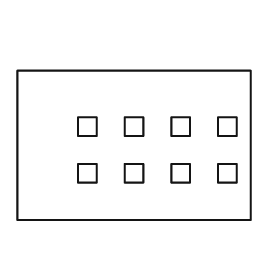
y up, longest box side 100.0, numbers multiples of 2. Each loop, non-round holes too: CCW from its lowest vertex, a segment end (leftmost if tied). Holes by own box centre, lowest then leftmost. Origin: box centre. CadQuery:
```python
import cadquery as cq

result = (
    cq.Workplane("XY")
    .moveTo(-50.0, -32.0)
    .lineTo(50.0, -32.0)
    .lineTo(50.0, 32.0)
    .lineTo(-50.0, 32.0)
    .close()
    .moveTo(-24.0, -16.0)
    .lineTo(-16.0, -16.0)
    .lineTo(-16.0, -8.0)
    .lineTo(-24.0, -8.0)
    .close()
    .moveTo(-4.0, -16.0)
    .lineTo(4.0, -16.0)
    .lineTo(4.0, -8.0)
    .lineTo(-4.0, -8.0)
    .close()
    .moveTo(16.0, -16.0)
    .lineTo(24.0, -16.0)
    .lineTo(24.0, -8.0)
    .lineTo(16.0, -8.0)
    .close()
    .moveTo(36.0, -16.0)
    .lineTo(44.0, -16.0)
    .lineTo(44.0, -8.0)
    .lineTo(36.0, -8.0)
    .close()
    .moveTo(-24.0, 4.0)
    .lineTo(-16.0, 4.0)
    .lineTo(-16.0, 12.0)
    .lineTo(-24.0, 12.0)
    .close()
    .moveTo(-4.0, 4.0)
    .lineTo(4.0, 4.0)
    .lineTo(4.0, 12.0)
    .lineTo(-4.0, 12.0)
    .close()
    .moveTo(16.0, 4.0)
    .lineTo(24.0, 4.0)
    .lineTo(24.0, 12.0)
    .lineTo(16.0, 12.0)
    .close()
    .moveTo(36.0, 4.0)
    .lineTo(44.0, 4.0)
    .lineTo(44.0, 12.0)
    .lineTo(36.0, 12.0)
    .close()
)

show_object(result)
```